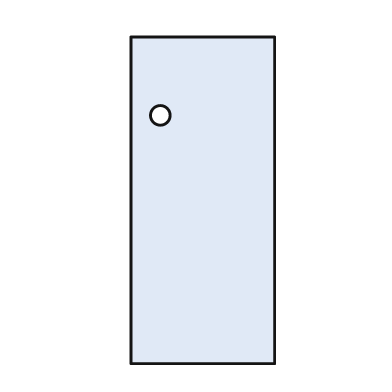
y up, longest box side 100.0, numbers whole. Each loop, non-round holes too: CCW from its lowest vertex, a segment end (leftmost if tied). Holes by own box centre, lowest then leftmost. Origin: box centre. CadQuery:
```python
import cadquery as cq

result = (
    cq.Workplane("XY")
    .moveTo(-22.0, -50.0)
    .lineTo(22.0, -50.0)
    .lineTo(22.0, 50.0)
    .lineTo(-22.0, 50.0)
    .close()
    .moveTo(-13.0, 26.0)
    .circle(3.0)
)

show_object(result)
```